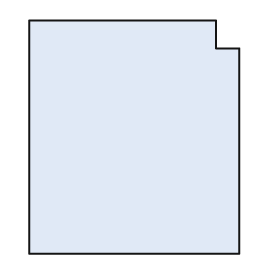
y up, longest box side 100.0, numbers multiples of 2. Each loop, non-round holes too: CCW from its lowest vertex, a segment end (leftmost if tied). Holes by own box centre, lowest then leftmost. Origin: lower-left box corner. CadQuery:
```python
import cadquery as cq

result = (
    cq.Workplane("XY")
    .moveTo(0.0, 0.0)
    .lineTo(90.0, 0.0)
    .lineTo(90.0, 88.0)
    .lineTo(80.0, 88.0)
    .lineTo(80.0, 100.0)
    .lineTo(0.0, 100.0)
    .close()
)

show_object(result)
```